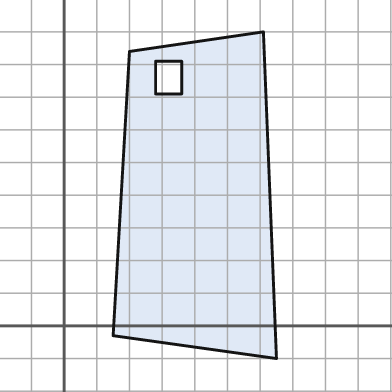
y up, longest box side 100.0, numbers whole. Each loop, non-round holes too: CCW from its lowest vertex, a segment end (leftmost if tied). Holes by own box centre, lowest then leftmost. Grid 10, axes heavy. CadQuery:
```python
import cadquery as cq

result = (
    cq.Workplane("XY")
    .moveTo(65.0, -10.0)
    .lineTo(61.0, 90.0)
    .lineTo(20.0, 84.0)
    .lineTo(15.0, -3.0)
    .close()
    .moveTo(28.0, 71.0)
    .lineTo(36.0, 71.0)
    .lineTo(36.0, 81.0)
    .lineTo(28.0, 81.0)
    .close()
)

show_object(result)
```